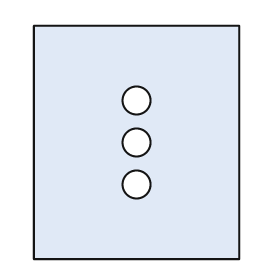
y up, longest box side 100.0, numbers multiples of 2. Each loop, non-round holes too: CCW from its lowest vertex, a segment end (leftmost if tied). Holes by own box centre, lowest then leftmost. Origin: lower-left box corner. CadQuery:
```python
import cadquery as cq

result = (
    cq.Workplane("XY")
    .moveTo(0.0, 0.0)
    .lineTo(88.0, 0.0)
    .lineTo(88.0, 100.0)
    .lineTo(0.0, 100.0)
    .close()
    .moveTo(44.0, 32.0)
    .circle(6.0)
    .moveTo(44.0, 50.0)
    .circle(6.0)
    .moveTo(44.0, 68.0)
    .circle(6.0)
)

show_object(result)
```